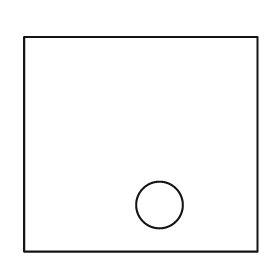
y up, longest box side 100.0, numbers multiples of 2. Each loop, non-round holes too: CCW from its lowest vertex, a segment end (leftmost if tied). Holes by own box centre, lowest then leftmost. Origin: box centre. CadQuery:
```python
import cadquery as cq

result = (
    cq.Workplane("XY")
    .moveTo(-50.0, -46.0)
    .lineTo(50.0, -46.0)
    .lineTo(50.0, 46.0)
    .lineTo(-50.0, 46.0)
    .close()
    .moveTo(8.0, -26.0)
    .circle(10.0)
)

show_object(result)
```